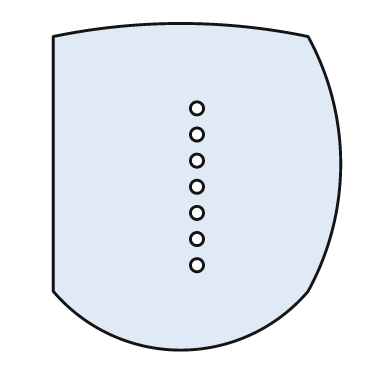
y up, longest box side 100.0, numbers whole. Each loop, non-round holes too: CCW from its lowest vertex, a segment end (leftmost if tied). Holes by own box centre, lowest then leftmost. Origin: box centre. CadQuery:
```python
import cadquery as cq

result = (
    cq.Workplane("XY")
    .moveTo(-44.0, -32.0)
    .threePointArc((-5.0, -50.0), (34.0, -32.0))
    .threePointArc((44.0, 7.0), (34.0, 46.0))
    .threePointArc((-5.0, 50.0), (-44.0, 46.0))
    .close()
    .moveTo(0.0, -24.0)
    .circle(2.0)
    .moveTo(0.0, -16.0)
    .circle(2.0)
    .moveTo(0.0, -8.0)
    .circle(2.0)
    .moveTo(0.0, 0.0)
    .circle(2.0)
    .moveTo(0.0, 8.0)
    .circle(2.0)
    .moveTo(0.0, 16.0)
    .circle(2.0)
    .moveTo(0.0, 24.0)
    .circle(2.0)
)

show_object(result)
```